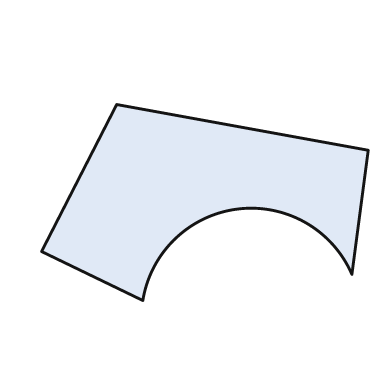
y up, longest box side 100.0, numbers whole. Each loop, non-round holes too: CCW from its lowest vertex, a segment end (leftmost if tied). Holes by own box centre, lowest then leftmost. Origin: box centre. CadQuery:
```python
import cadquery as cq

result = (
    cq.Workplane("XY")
    .moveTo(-19.0, -30.0)
    .threePointArc((10.0, -2.0), (45.0, -22.0))
    .lineTo(50.0, 16.0)
    .lineTo(-27.0, 30.0)
    .lineTo(-50.0, -15.0)
    .close()
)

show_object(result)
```